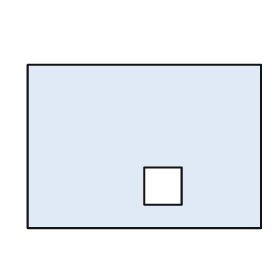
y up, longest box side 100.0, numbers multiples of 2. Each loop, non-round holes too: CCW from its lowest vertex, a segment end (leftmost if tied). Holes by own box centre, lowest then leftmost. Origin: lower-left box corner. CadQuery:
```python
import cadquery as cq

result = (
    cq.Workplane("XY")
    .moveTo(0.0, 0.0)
    .lineTo(100.0, 0.0)
    .lineTo(100.0, 70.0)
    .lineTo(0.0, 70.0)
    .close()
    .moveTo(50.0, 10.0)
    .lineTo(66.0, 10.0)
    .lineTo(66.0, 26.0)
    .lineTo(50.0, 26.0)
    .close()
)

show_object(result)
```